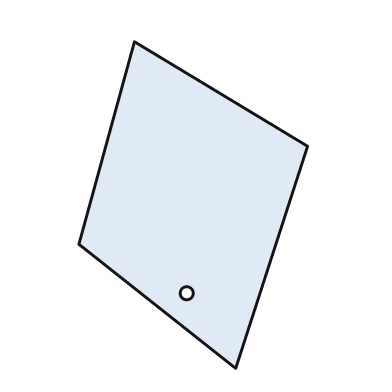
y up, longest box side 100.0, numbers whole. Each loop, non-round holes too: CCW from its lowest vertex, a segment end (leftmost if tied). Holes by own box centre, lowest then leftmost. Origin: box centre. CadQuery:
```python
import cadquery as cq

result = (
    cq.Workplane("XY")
    .moveTo(13.0, -50.0)
    .lineTo(35.0, 18.0)
    .lineTo(-18.0, 50.0)
    .lineTo(-35.0, -12.0)
    .close()
    .moveTo(-2.0, -27.0)
    .circle(2.0)
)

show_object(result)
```